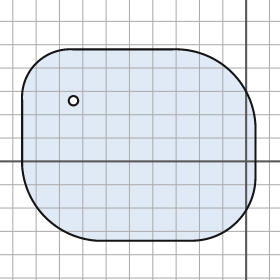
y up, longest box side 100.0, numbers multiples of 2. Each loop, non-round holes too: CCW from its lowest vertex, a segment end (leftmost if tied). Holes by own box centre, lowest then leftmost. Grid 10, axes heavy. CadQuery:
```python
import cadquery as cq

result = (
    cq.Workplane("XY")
    .moveTo(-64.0, -34.0)
    .lineTo(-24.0, -34.0)
    .threePointArc((-4.0, -26.0), (4.0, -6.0))
    .lineTo(4.0, 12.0)
    .threePointArc((-6.0, 38.0), (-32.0, 48.0))
    .lineTo(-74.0, 48.0)
    .threePointArc((-90.0, 42.0), (-96.0, 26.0))
    .lineTo(-96.0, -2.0)
    .threePointArc((-86.0, -24.0), (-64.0, -34.0))
    .close()
    .moveTo(-74.0, 26.0)
    .circle(2.0)
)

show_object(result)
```